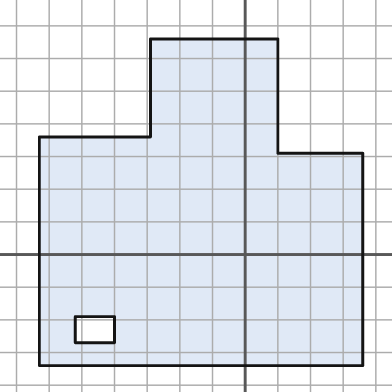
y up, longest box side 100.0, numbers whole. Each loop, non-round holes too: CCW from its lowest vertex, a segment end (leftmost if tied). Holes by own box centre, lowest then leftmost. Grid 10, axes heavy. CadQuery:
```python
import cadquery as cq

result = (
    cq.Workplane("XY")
    .moveTo(-63.0, -34.0)
    .lineTo(36.0, -34.0)
    .lineTo(36.0, 31.0)
    .lineTo(10.0, 31.0)
    .lineTo(10.0, 66.0)
    .lineTo(-29.0, 66.0)
    .lineTo(-29.0, 36.0)
    .lineTo(-63.0, 36.0)
    .close()
    .moveTo(-52.0, -27.0)
    .lineTo(-40.0, -27.0)
    .lineTo(-40.0, -19.0)
    .lineTo(-52.0, -19.0)
    .close()
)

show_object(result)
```